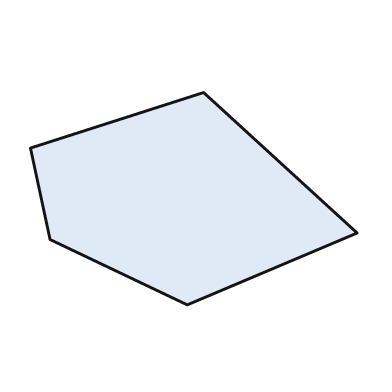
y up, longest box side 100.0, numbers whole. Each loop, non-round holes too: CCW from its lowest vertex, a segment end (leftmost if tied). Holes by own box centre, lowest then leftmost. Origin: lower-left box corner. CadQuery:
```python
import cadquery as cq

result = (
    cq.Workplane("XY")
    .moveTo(48.0, 0.0)
    .lineTo(100.0, 22.0)
    .lineTo(53.0, 65.0)
    .lineTo(0.0, 48.0)
    .lineTo(6.0, 20.0)
    .close()
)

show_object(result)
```